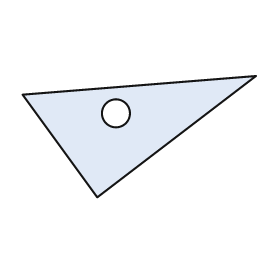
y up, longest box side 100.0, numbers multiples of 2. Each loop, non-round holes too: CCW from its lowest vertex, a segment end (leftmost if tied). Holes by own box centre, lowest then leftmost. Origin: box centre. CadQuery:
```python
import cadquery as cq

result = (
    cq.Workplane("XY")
    .moveTo(-18.0, -26.0)
    .lineTo(50.0, 26.0)
    .lineTo(-50.0, 18.0)
    .close()
    .moveTo(-10.0, 10.0)
    .circle(6.0)
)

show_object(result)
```